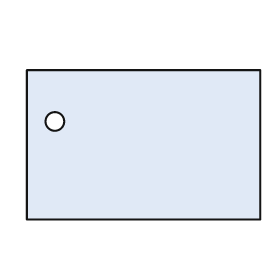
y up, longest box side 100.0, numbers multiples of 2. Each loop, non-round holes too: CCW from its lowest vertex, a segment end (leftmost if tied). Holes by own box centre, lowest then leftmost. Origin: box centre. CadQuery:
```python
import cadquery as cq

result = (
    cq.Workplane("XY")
    .moveTo(-50.0, -32.0)
    .lineTo(50.0, -32.0)
    .lineTo(50.0, 32.0)
    .lineTo(-50.0, 32.0)
    .close()
    .moveTo(-38.0, 10.0)
    .circle(4.0)
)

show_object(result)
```